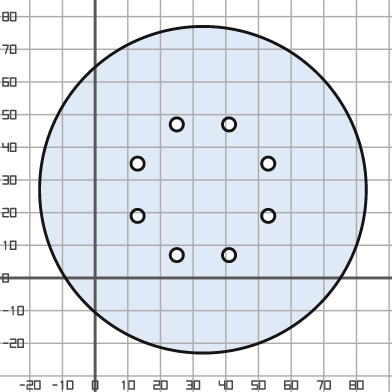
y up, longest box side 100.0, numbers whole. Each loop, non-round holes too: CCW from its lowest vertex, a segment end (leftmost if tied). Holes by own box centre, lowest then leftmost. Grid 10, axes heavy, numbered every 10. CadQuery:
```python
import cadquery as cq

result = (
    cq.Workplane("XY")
    .moveTo(33.0, 27.0)
    .circle(50.0)
    .moveTo(25.0, 7.0)
    .circle(2.0)
    .moveTo(41.0, 7.0)
    .circle(2.0)
    .moveTo(13.0, 19.0)
    .circle(2.0)
    .moveTo(53.0, 19.0)
    .circle(2.0)
    .moveTo(13.0, 35.0)
    .circle(2.0)
    .moveTo(53.0, 35.0)
    .circle(2.0)
    .moveTo(25.0, 47.0)
    .circle(2.0)
    .moveTo(41.0, 47.0)
    .circle(2.0)
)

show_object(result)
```